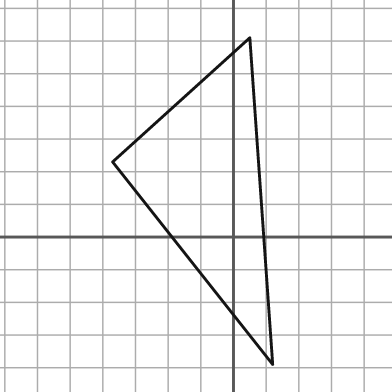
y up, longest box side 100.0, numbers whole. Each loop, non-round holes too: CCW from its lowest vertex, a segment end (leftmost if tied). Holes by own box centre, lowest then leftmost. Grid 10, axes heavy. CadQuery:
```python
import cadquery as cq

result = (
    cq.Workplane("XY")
    .moveTo(12.0, -39.0)
    .lineTo(5.0, 61.0)
    .lineTo(-37.0, 23.0)
    .close()
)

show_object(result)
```